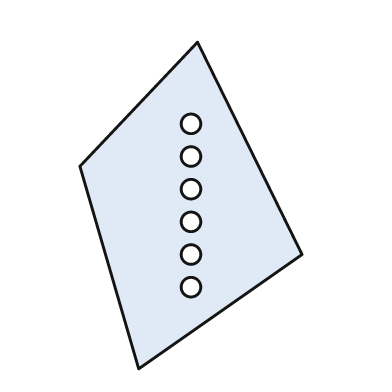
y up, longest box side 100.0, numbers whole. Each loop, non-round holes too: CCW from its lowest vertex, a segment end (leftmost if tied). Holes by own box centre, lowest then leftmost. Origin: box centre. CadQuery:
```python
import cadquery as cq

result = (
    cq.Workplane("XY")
    .moveTo(-16.0, -50.0)
    .lineTo(34.0, -15.0)
    .lineTo(2.0, 50.0)
    .lineTo(-34.0, 12.0)
    .close()
    .moveTo(0.0, -25.0)
    .circle(3.0)
    .moveTo(0.0, -15.0)
    .circle(3.0)
    .moveTo(0.0, -5.0)
    .circle(3.0)
    .moveTo(0.0, 5.0)
    .circle(3.0)
    .moveTo(0.0, 15.0)
    .circle(3.0)
    .moveTo(0.0, 25.0)
    .circle(3.0)
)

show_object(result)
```